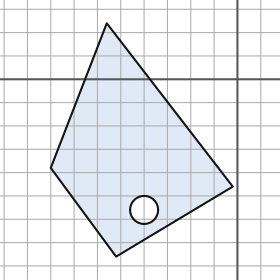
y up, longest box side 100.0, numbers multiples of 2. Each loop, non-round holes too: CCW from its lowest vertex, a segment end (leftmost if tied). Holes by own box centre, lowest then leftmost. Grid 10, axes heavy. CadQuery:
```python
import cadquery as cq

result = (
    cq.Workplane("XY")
    .moveTo(-52.0, -76.0)
    .lineTo(-2.0, -46.0)
    .lineTo(-56.0, 24.0)
    .lineTo(-80.0, -38.0)
    .close()
    .moveTo(-40.0, -56.0)
    .circle(6.0)
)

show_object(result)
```